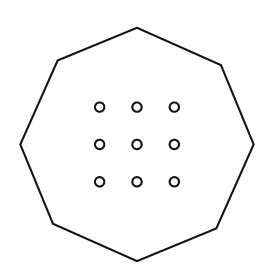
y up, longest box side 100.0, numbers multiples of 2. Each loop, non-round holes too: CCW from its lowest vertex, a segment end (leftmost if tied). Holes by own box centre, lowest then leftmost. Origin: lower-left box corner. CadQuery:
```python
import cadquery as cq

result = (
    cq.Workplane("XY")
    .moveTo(50.0, 0.0)
    .lineTo(84.0, 14.0)
    .lineTo(100.0, 50.0)
    .lineTo(86.0, 84.0)
    .lineTo(50.0, 100.0)
    .lineTo(16.0, 86.0)
    .lineTo(0.0, 50.0)
    .lineTo(14.0, 16.0)
    .close()
    .moveTo(34.0, 34.0)
    .circle(2.0)
    .moveTo(50.0, 34.0)
    .circle(2.0)
    .moveTo(66.0, 34.0)
    .circle(2.0)
    .moveTo(34.0, 50.0)
    .circle(2.0)
    .moveTo(50.0, 50.0)
    .circle(2.0)
    .moveTo(66.0, 50.0)
    .circle(2.0)
    .moveTo(34.0, 66.0)
    .circle(2.0)
    .moveTo(50.0, 66.0)
    .circle(2.0)
    .moveTo(66.0, 66.0)
    .circle(2.0)
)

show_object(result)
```